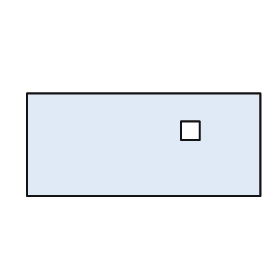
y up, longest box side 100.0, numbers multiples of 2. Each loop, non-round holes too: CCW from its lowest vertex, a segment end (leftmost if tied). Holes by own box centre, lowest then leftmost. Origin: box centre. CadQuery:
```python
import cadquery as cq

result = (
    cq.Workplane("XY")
    .moveTo(-50.0, -22.0)
    .lineTo(50.0, -22.0)
    .lineTo(50.0, 22.0)
    .lineTo(-50.0, 22.0)
    .close()
    .moveTo(16.0, 2.0)
    .lineTo(24.0, 2.0)
    .lineTo(24.0, 10.0)
    .lineTo(16.0, 10.0)
    .close()
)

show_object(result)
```